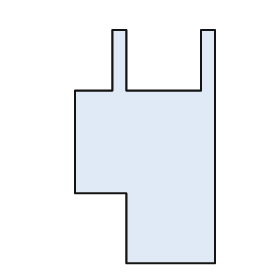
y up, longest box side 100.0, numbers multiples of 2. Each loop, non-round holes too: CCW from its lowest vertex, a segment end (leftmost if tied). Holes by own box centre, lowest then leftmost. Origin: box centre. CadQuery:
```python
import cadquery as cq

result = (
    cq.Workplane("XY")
    .moveTo(-8.0, -50.0)
    .lineTo(30.0, -50.0)
    .lineTo(30.0, 50.0)
    .lineTo(24.0, 50.0)
    .lineTo(24.0, 24.0)
    .lineTo(-8.0, 24.0)
    .lineTo(-8.0, 50.0)
    .lineTo(-14.0, 50.0)
    .lineTo(-14.0, 24.0)
    .lineTo(-30.0, 24.0)
    .lineTo(-30.0, -20.0)
    .lineTo(-8.0, -20.0)
    .close()
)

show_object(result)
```